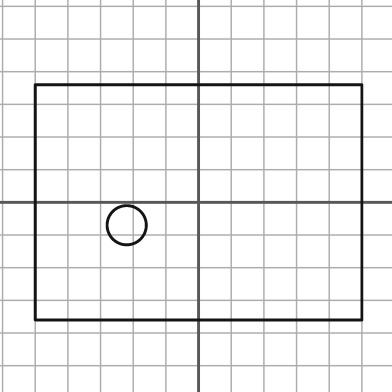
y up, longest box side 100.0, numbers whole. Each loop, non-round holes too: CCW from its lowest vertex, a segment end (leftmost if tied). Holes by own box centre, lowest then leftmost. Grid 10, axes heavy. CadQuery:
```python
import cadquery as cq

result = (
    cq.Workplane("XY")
    .moveTo(-50.0, -36.0)
    .lineTo(50.0, -36.0)
    .lineTo(50.0, 36.0)
    .lineTo(-50.0, 36.0)
    .close()
    .moveTo(-22.0, -7.0)
    .circle(6.0)
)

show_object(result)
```